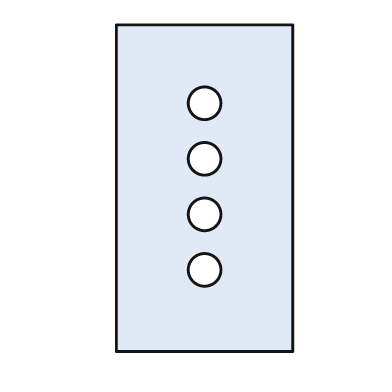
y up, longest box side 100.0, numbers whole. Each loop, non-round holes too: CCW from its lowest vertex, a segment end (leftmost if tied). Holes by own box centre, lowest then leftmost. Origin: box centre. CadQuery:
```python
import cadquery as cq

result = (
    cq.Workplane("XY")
    .moveTo(-27.0, -50.0)
    .lineTo(27.0, -50.0)
    .lineTo(27.0, 50.0)
    .lineTo(-27.0, 50.0)
    .close()
    .moveTo(0.0, -25.0)
    .circle(5.0)
    .moveTo(0.0, -8.0)
    .circle(5.0)
    .moveTo(0.0, 9.0)
    .circle(5.0)
    .moveTo(0.0, 26.0)
    .circle(5.0)
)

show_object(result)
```